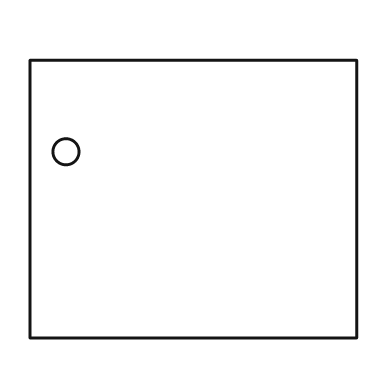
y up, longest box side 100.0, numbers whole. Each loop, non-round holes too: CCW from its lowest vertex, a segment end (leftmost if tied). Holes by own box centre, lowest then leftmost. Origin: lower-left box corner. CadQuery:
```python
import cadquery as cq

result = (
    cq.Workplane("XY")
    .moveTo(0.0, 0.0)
    .lineTo(100.0, 0.0)
    .lineTo(100.0, 85.0)
    .lineTo(0.0, 85.0)
    .close()
    .moveTo(11.0, 57.0)
    .circle(4.0)
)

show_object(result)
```